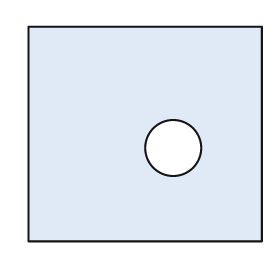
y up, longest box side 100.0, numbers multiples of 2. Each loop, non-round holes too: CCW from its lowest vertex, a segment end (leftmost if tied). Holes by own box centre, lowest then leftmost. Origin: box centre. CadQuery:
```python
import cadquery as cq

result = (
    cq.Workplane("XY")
    .moveTo(-50.0, -46.0)
    .lineTo(50.0, -46.0)
    .lineTo(50.0, 46.0)
    .lineTo(-50.0, 46.0)
    .close()
    .moveTo(12.0, -6.0)
    .circle(12.0)
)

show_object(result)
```